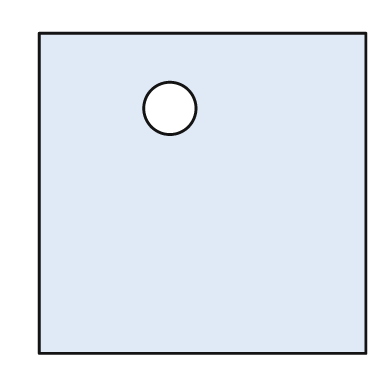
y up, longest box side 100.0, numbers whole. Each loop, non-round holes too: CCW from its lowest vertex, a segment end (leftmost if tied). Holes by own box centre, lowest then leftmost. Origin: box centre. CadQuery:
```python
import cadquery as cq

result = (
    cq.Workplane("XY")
    .moveTo(-50.0, -49.0)
    .lineTo(50.0, -49.0)
    .lineTo(50.0, 49.0)
    .lineTo(-50.0, 49.0)
    .close()
    .moveTo(-10.0, 26.0)
    .circle(8.0)
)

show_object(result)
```